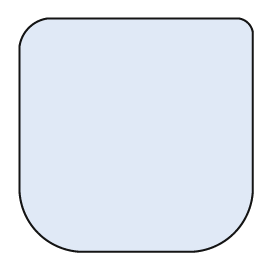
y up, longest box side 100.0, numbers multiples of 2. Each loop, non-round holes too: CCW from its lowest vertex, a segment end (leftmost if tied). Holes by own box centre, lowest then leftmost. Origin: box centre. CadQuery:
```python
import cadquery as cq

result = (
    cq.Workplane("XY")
    .moveTo(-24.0, -50.0)
    .lineTo(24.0, -50.0)
    .threePointArc((42.0, -42.0), (50.0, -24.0))
    .lineTo(50.0, 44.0)
    .threePointArc((48.0, 48.0), (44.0, 50.0))
    .lineTo(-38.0, 50.0)
    .threePointArc((-46.0, 46.0), (-50.0, 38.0))
    .lineTo(-50.0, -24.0)
    .threePointArc((-42.0, -42.0), (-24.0, -50.0))
    .close()
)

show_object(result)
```